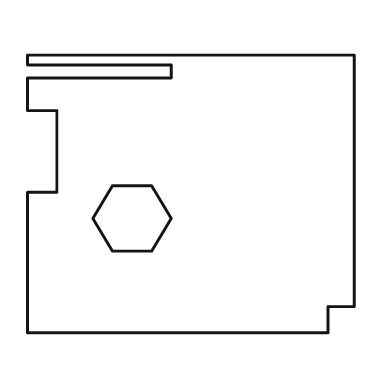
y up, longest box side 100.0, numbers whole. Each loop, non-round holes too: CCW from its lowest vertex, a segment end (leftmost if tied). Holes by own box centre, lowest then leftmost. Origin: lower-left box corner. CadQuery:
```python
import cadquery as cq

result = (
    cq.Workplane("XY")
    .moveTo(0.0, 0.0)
    .lineTo(92.0, 0.0)
    .lineTo(92.0, 8.0)
    .lineTo(100.0, 8.0)
    .lineTo(100.0, 85.0)
    .lineTo(0.0, 85.0)
    .lineTo(0.0, 82.0)
    .lineTo(44.0, 82.0)
    .lineTo(44.0, 78.0)
    .lineTo(0.0, 78.0)
    .lineTo(0.0, 68.0)
    .lineTo(9.0, 68.0)
    .lineTo(9.0, 43.0)
    .lineTo(0.0, 43.0)
    .close()
    .moveTo(26.0, 25.0)
    .lineTo(38.0, 25.0)
    .lineTo(44.0, 35.0)
    .lineTo(38.0, 45.0)
    .lineTo(26.0, 45.0)
    .lineTo(20.0, 35.0)
    .close()
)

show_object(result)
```